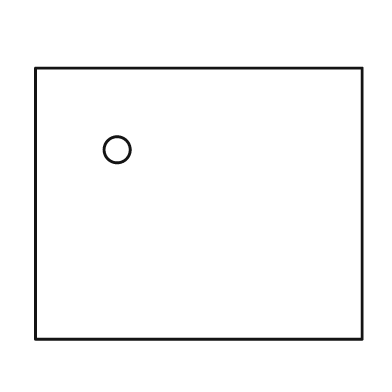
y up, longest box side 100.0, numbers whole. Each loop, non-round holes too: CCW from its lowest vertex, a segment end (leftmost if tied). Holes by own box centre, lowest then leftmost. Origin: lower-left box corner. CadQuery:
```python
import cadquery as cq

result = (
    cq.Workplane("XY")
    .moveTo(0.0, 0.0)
    .lineTo(100.0, 0.0)
    .lineTo(100.0, 83.0)
    .lineTo(0.0, 83.0)
    .close()
    .moveTo(25.0, 58.0)
    .circle(4.0)
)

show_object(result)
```